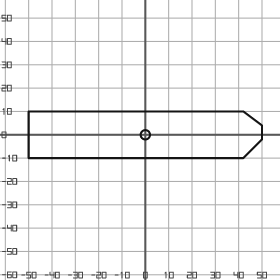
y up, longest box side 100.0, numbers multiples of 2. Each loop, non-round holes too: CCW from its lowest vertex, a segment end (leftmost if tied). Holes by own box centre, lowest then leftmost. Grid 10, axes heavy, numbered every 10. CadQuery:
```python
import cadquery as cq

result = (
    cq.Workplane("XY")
    .moveTo(-50.0, -10.0)
    .lineTo(42.0, -10.0)
    .lineTo(50.0, -2.0)
    .lineTo(50.0, 4.0)
    .lineTo(42.0, 10.0)
    .lineTo(-50.0, 10.0)
    .close()
    .moveTo(0.0, 0.0)
    .circle(2.0)
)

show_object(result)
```